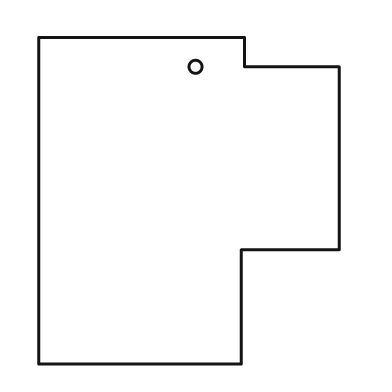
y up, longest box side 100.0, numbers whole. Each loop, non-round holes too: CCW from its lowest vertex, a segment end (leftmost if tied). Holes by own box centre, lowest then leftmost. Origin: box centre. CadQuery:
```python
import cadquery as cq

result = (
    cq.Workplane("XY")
    .moveTo(-46.0, -50.0)
    .lineTo(16.0, -50.0)
    .lineTo(16.0, -15.0)
    .lineTo(46.0, -15.0)
    .lineTo(46.0, 41.0)
    .lineTo(17.0, 41.0)
    .lineTo(17.0, 50.0)
    .lineTo(-46.0, 50.0)
    .close()
    .moveTo(2.0, 41.0)
    .circle(2.0)
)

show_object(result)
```